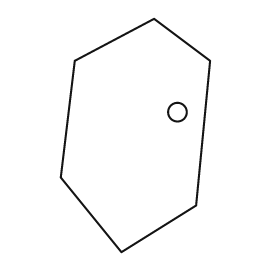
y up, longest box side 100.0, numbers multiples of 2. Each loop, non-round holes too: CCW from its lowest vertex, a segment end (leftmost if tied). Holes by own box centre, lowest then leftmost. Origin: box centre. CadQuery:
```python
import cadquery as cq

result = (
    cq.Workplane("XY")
    .moveTo(-6.0, -50.0)
    .lineTo(26.0, -30.0)
    .lineTo(32.0, 32.0)
    .lineTo(8.0, 50.0)
    .lineTo(-26.0, 32.0)
    .lineTo(-32.0, -18.0)
    .close()
    .moveTo(18.0, 10.0)
    .circle(4.0)
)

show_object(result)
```